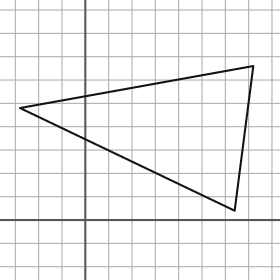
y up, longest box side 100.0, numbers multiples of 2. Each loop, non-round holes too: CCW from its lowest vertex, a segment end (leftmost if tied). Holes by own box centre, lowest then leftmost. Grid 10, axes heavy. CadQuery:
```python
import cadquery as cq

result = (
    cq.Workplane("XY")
    .moveTo(64.0, 4.0)
    .lineTo(72.0, 66.0)
    .lineTo(-28.0, 48.0)
    .close()
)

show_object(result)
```